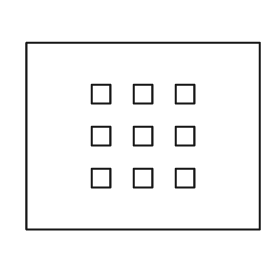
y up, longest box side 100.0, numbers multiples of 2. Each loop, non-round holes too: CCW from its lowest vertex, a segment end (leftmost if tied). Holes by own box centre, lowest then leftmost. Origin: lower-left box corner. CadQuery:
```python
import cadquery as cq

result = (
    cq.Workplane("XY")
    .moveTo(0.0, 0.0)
    .lineTo(100.0, 0.0)
    .lineTo(100.0, 80.0)
    .lineTo(0.0, 80.0)
    .close()
    .moveTo(28.0, 18.0)
    .lineTo(36.0, 18.0)
    .lineTo(36.0, 26.0)
    .lineTo(28.0, 26.0)
    .close()
    .moveTo(46.0, 18.0)
    .lineTo(54.0, 18.0)
    .lineTo(54.0, 26.0)
    .lineTo(46.0, 26.0)
    .close()
    .moveTo(64.0, 18.0)
    .lineTo(72.0, 18.0)
    .lineTo(72.0, 26.0)
    .lineTo(64.0, 26.0)
    .close()
    .moveTo(28.0, 36.0)
    .lineTo(36.0, 36.0)
    .lineTo(36.0, 44.0)
    .lineTo(28.0, 44.0)
    .close()
    .moveTo(46.0, 36.0)
    .lineTo(54.0, 36.0)
    .lineTo(54.0, 44.0)
    .lineTo(46.0, 44.0)
    .close()
    .moveTo(64.0, 36.0)
    .lineTo(72.0, 36.0)
    .lineTo(72.0, 44.0)
    .lineTo(64.0, 44.0)
    .close()
    .moveTo(28.0, 54.0)
    .lineTo(36.0, 54.0)
    .lineTo(36.0, 62.0)
    .lineTo(28.0, 62.0)
    .close()
    .moveTo(46.0, 54.0)
    .lineTo(54.0, 54.0)
    .lineTo(54.0, 62.0)
    .lineTo(46.0, 62.0)
    .close()
    .moveTo(64.0, 54.0)
    .lineTo(72.0, 54.0)
    .lineTo(72.0, 62.0)
    .lineTo(64.0, 62.0)
    .close()
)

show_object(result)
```